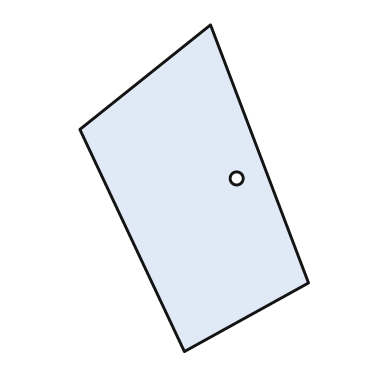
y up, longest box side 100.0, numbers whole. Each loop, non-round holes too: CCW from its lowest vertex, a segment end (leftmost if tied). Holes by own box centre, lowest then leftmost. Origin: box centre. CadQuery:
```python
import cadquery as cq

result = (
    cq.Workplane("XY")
    .moveTo(-3.0, -50.0)
    .lineTo(35.0, -29.0)
    .lineTo(5.0, 50.0)
    .lineTo(-35.0, 18.0)
    .close()
    .moveTo(13.0, 3.0)
    .circle(2.0)
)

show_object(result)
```